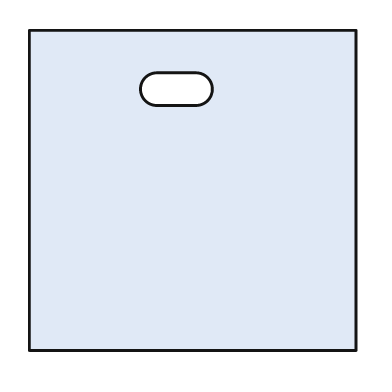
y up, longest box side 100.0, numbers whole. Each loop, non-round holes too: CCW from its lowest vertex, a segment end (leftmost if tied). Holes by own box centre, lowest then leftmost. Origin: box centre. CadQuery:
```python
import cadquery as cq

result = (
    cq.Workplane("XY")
    .moveTo(-50.0, -49.0)
    .lineTo(50.0, -49.0)
    .lineTo(50.0, 49.0)
    .lineTo(-50.0, 49.0)
    .close()
    .moveTo(-11.0, 26.0)
    .lineTo(1.0, 26.0)
    .threePointArc((6.0, 31.0), (1.0, 36.0))
    .lineTo(-11.0, 36.0)
    .threePointArc((-16.0, 31.0), (-11.0, 26.0))
    .close()
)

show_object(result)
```